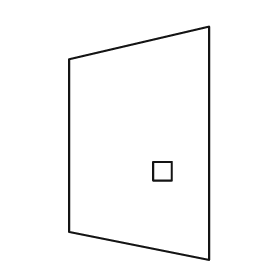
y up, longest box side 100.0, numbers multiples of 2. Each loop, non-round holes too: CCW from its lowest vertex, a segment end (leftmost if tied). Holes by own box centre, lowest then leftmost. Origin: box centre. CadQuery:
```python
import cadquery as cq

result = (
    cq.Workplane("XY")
    .moveTo(30.0, -50.0)
    .lineTo(30.0, 50.0)
    .lineTo(-30.0, 36.0)
    .lineTo(-30.0, -38.0)
    .close()
    .moveTo(6.0, -16.0)
    .lineTo(14.0, -16.0)
    .lineTo(14.0, -8.0)
    .lineTo(6.0, -8.0)
    .close()
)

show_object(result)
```